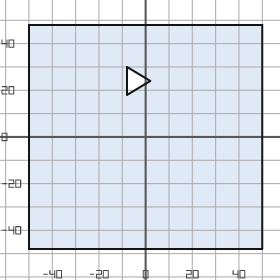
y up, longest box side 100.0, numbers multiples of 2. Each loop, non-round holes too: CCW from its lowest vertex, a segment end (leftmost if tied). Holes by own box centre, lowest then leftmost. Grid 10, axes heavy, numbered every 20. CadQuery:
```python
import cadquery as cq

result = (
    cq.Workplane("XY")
    .moveTo(-50.0, -48.0)
    .lineTo(50.0, -48.0)
    .lineTo(50.0, 48.0)
    .lineTo(-50.0, 48.0)
    .close()
    .moveTo(-8.0, 18.0)
    .lineTo(2.0, 24.0)
    .lineTo(-8.0, 30.0)
    .close()
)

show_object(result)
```